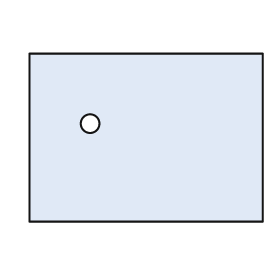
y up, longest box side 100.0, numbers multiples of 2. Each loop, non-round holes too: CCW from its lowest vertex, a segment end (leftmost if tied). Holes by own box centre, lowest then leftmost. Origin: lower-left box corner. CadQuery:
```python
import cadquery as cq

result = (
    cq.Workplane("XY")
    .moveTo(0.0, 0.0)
    .lineTo(100.0, 0.0)
    .lineTo(100.0, 72.0)
    .lineTo(0.0, 72.0)
    .close()
    .moveTo(26.0, 42.0)
    .circle(4.0)
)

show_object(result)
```